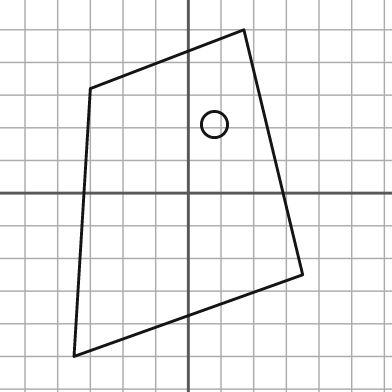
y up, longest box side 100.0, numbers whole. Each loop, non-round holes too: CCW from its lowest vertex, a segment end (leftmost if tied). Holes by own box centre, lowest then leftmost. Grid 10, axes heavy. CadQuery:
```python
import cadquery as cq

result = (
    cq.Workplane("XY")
    .moveTo(-35.0, -50.0)
    .lineTo(35.0, -25.0)
    .lineTo(17.0, 50.0)
    .lineTo(-30.0, 32.0)
    .close()
    .moveTo(8.0, 21.0)
    .circle(4.0)
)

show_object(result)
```